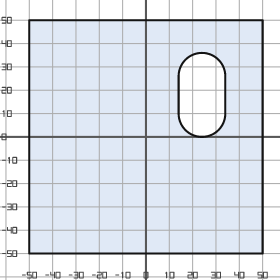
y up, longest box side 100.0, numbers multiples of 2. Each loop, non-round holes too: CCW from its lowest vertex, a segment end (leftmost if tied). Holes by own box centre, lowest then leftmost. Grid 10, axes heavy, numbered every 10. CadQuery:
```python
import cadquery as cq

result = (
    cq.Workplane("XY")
    .moveTo(-50.0, -50.0)
    .lineTo(50.0, -50.0)
    .lineTo(50.0, 50.0)
    .lineTo(-50.0, 50.0)
    .close()
    .moveTo(14.0, 10.0)
    .threePointArc((24.0, 0.0), (34.0, 10.0))
    .lineTo(34.0, 26.0)
    .threePointArc((24.0, 36.0), (14.0, 26.0))
    .close()
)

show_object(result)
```